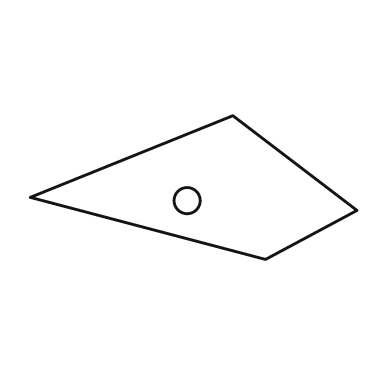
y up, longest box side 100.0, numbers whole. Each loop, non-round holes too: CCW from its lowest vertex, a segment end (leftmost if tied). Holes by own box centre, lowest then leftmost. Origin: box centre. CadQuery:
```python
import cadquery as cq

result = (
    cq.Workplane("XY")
    .moveTo(22.0, -22.0)
    .lineTo(50.0, -7.0)
    .lineTo(12.0, 22.0)
    .lineTo(-50.0, -3.0)
    .close()
    .moveTo(-2.0, -4.0)
    .circle(4.0)
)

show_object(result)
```